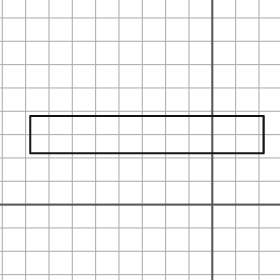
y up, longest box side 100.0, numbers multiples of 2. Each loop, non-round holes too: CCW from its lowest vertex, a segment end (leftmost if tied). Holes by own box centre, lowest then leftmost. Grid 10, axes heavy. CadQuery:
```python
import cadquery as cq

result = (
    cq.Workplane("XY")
    .moveTo(-78.0, 22.0)
    .lineTo(22.0, 22.0)
    .lineTo(22.0, 38.0)
    .lineTo(-78.0, 38.0)
    .close()
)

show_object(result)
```